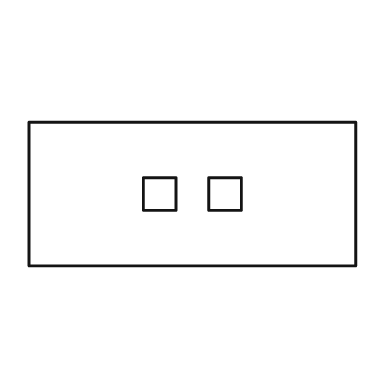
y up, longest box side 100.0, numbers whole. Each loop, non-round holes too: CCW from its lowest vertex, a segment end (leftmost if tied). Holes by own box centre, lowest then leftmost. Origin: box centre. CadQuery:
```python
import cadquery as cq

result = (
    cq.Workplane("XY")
    .moveTo(-50.0, -22.0)
    .lineTo(50.0, -22.0)
    .lineTo(50.0, 22.0)
    .lineTo(-50.0, 22.0)
    .close()
    .moveTo(-15.0, -5.0)
    .lineTo(-5.0, -5.0)
    .lineTo(-5.0, 5.0)
    .lineTo(-15.0, 5.0)
    .close()
    .moveTo(5.0, -5.0)
    .lineTo(15.0, -5.0)
    .lineTo(15.0, 5.0)
    .lineTo(5.0, 5.0)
    .close()
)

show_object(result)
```